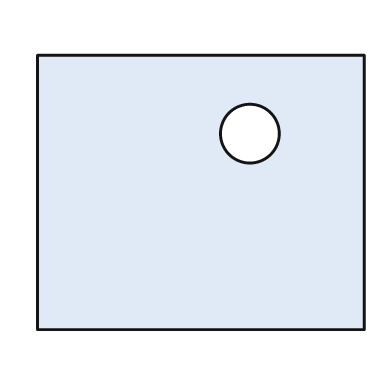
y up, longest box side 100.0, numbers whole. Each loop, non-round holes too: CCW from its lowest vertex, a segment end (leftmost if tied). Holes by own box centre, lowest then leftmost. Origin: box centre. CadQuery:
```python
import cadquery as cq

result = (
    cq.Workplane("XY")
    .moveTo(-50.0, -42.0)
    .lineTo(50.0, -42.0)
    .lineTo(50.0, 42.0)
    .lineTo(-50.0, 42.0)
    .close()
    .moveTo(15.0, 18.0)
    .circle(9.0)
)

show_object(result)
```